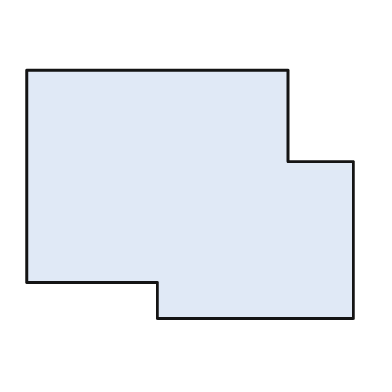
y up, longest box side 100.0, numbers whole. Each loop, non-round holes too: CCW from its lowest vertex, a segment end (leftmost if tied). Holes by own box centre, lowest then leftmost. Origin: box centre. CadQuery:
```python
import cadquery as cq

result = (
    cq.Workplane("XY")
    .moveTo(-10.0, -38.0)
    .lineTo(50.0, -38.0)
    .lineTo(50.0, 10.0)
    .lineTo(30.0, 10.0)
    .lineTo(30.0, 38.0)
    .lineTo(-50.0, 38.0)
    .lineTo(-50.0, -27.0)
    .lineTo(-10.0, -27.0)
    .close()
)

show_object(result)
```